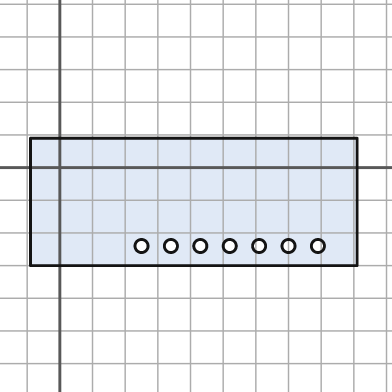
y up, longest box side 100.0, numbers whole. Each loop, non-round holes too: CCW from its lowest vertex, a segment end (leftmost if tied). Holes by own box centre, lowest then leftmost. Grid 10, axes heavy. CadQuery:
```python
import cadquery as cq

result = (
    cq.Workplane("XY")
    .moveTo(-9.0, -30.0)
    .lineTo(91.0, -30.0)
    .lineTo(91.0, 9.0)
    .lineTo(-9.0, 9.0)
    .close()
    .moveTo(25.0, -24.0)
    .circle(2.0)
    .moveTo(34.0, -24.0)
    .circle(2.0)
    .moveTo(43.0, -24.0)
    .circle(2.0)
    .moveTo(52.0, -24.0)
    .circle(2.0)
    .moveTo(61.0, -24.0)
    .circle(2.0)
    .moveTo(70.0, -24.0)
    .circle(2.0)
    .moveTo(79.0, -24.0)
    .circle(2.0)
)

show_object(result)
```